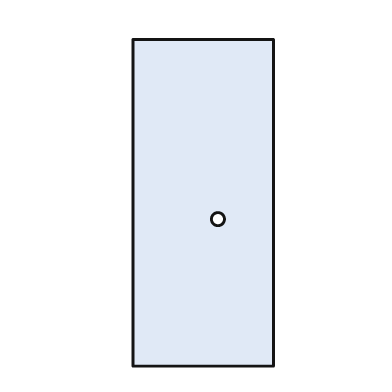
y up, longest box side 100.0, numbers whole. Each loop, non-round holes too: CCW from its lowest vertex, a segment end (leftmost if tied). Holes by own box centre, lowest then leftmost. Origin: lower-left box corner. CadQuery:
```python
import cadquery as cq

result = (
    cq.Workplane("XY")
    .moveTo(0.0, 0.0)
    .lineTo(43.0, 0.0)
    .lineTo(43.0, 100.0)
    .lineTo(0.0, 100.0)
    .close()
    .moveTo(26.0, 45.0)
    .circle(2.0)
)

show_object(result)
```